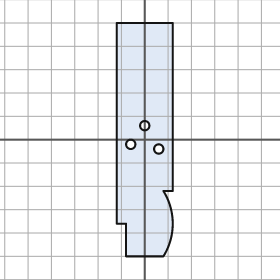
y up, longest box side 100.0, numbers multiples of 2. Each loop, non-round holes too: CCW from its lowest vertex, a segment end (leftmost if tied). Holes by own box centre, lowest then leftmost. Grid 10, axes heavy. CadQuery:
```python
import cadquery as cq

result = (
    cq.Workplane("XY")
    .moveTo(-8.0, -50.0)
    .lineTo(8.0, -50.0)
    .threePointArc((12.0, -36.0), (8.0, -22.0))
    .lineTo(12.0, -22.0)
    .lineTo(12.0, 50.0)
    .lineTo(-12.0, 50.0)
    .lineTo(-12.0, -36.0)
    .lineTo(-8.0, -36.0)
    .close()
    .moveTo(6.0, -4.0)
    .circle(2.0)
    .moveTo(-6.0, -2.0)
    .circle(2.0)
    .moveTo(0.0, 6.0)
    .circle(2.0)
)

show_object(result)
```